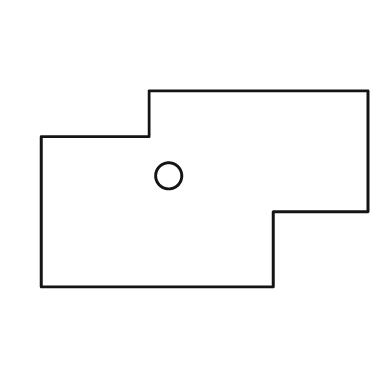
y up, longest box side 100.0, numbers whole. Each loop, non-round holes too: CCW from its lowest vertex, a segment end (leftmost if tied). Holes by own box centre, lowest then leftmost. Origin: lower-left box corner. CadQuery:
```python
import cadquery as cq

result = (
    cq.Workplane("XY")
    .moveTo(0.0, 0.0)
    .lineTo(71.0, 0.0)
    .lineTo(71.0, 23.0)
    .lineTo(100.0, 23.0)
    .lineTo(100.0, 60.0)
    .lineTo(33.0, 60.0)
    .lineTo(33.0, 46.0)
    .lineTo(0.0, 46.0)
    .close()
    .moveTo(39.0, 34.0)
    .circle(4.0)
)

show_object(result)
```